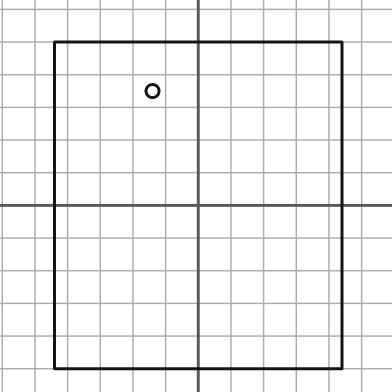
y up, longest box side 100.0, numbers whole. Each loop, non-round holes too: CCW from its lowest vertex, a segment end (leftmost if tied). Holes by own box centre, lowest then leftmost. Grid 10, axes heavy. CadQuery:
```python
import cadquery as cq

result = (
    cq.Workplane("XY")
    .moveTo(-44.0, -50.0)
    .lineTo(44.0, -50.0)
    .lineTo(44.0, 50.0)
    .lineTo(-44.0, 50.0)
    .close()
    .moveTo(-14.0, 35.0)
    .circle(2.0)
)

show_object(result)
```